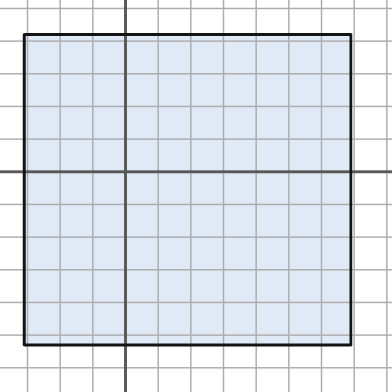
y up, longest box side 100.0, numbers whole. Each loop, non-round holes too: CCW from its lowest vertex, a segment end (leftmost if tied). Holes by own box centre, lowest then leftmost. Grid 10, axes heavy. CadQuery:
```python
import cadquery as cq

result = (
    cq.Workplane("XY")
    .moveTo(-31.0, -53.0)
    .lineTo(69.0, -53.0)
    .lineTo(69.0, 42.0)
    .lineTo(-31.0, 42.0)
    .close()
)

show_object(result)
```